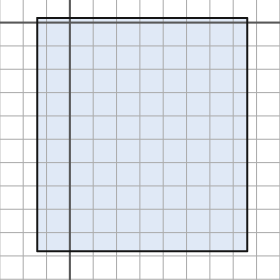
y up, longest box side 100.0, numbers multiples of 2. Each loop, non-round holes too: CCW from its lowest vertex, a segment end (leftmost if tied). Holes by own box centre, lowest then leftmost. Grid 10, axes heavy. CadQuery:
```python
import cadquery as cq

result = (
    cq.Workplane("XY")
    .moveTo(-14.0, -98.0)
    .lineTo(76.0, -98.0)
    .lineTo(76.0, 2.0)
    .lineTo(-14.0, 2.0)
    .close()
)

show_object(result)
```